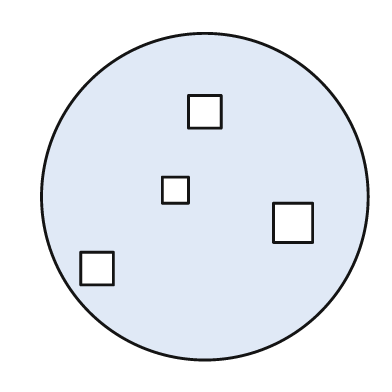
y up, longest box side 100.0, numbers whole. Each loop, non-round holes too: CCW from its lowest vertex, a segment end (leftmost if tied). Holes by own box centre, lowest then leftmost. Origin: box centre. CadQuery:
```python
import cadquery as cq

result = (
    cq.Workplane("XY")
    .moveTo(0.0, 0.0)
    .circle(50.0)
    .moveTo(-38.0, -27.0)
    .lineTo(-28.0, -27.0)
    .lineTo(-28.0, -17.0)
    .lineTo(-38.0, -17.0)
    .close()
    .moveTo(21.0, -14.0)
    .lineTo(33.0, -14.0)
    .lineTo(33.0, -2.0)
    .lineTo(21.0, -2.0)
    .close()
    .moveTo(-13.0, -2.0)
    .lineTo(-5.0, -2.0)
    .lineTo(-5.0, 6.0)
    .lineTo(-13.0, 6.0)
    .close()
    .moveTo(-5.0, 21.0)
    .lineTo(5.0, 21.0)
    .lineTo(5.0, 31.0)
    .lineTo(-5.0, 31.0)
    .close()
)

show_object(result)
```